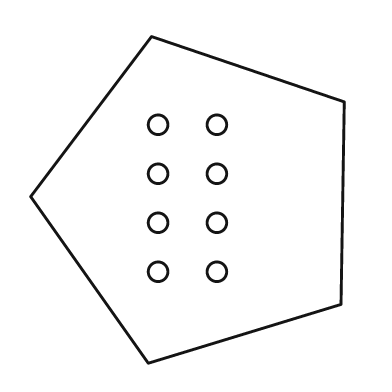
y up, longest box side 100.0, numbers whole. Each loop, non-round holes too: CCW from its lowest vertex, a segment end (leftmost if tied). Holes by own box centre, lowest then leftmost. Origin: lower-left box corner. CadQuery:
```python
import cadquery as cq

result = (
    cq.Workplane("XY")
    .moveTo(36.0, 0.0)
    .lineTo(95.0, 18.0)
    .lineTo(96.0, 80.0)
    .lineTo(37.0, 100.0)
    .lineTo(0.0, 51.0)
    .close()
    .moveTo(39.0, 28.0)
    .circle(3.0)
    .moveTo(57.0, 28.0)
    .circle(3.0)
    .moveTo(39.0, 43.0)
    .circle(3.0)
    .moveTo(57.0, 43.0)
    .circle(3.0)
    .moveTo(39.0, 58.0)
    .circle(3.0)
    .moveTo(57.0, 58.0)
    .circle(3.0)
    .moveTo(39.0, 73.0)
    .circle(3.0)
    .moveTo(57.0, 73.0)
    .circle(3.0)
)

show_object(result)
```